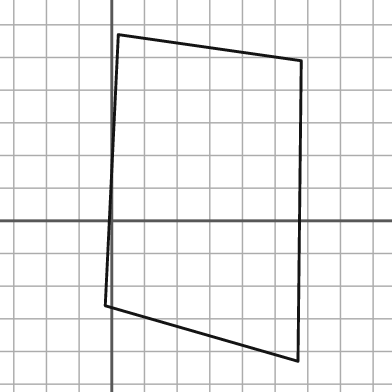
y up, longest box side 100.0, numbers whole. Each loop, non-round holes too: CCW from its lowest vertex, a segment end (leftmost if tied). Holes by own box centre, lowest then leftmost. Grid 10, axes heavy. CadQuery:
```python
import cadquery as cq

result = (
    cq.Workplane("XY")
    .moveTo(57.0, -43.0)
    .lineTo(58.0, 49.0)
    .lineTo(2.0, 57.0)
    .lineTo(-2.0, -26.0)
    .close()
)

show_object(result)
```